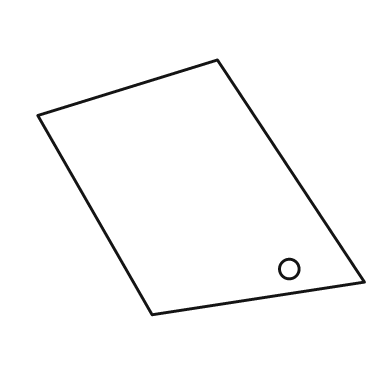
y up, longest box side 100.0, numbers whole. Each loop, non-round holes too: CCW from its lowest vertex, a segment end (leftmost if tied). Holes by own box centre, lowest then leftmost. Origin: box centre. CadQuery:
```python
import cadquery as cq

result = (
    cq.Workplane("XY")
    .moveTo(-15.0, -39.0)
    .lineTo(50.0, -29.0)
    .lineTo(5.0, 39.0)
    .lineTo(-50.0, 22.0)
    .close()
    .moveTo(27.0, -25.0)
    .circle(3.0)
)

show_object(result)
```